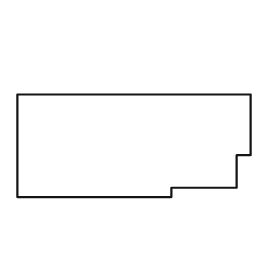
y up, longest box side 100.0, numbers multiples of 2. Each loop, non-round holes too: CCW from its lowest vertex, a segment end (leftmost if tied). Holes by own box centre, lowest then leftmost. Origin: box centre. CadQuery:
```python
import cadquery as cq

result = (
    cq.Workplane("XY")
    .moveTo(-50.0, -22.0)
    .lineTo(16.0, -22.0)
    .lineTo(16.0, -18.0)
    .lineTo(44.0, -18.0)
    .lineTo(44.0, -4.0)
    .lineTo(50.0, -4.0)
    .lineTo(50.0, 22.0)
    .lineTo(-50.0, 22.0)
    .close()
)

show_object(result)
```